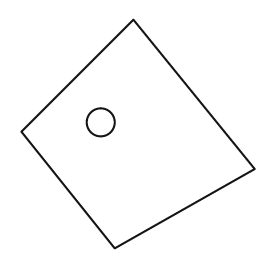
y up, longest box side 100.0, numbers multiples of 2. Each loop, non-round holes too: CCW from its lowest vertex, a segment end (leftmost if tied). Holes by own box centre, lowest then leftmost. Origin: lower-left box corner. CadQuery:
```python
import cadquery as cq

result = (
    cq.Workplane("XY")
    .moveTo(40.0, 0.0)
    .lineTo(100.0, 34.0)
    .lineTo(48.0, 98.0)
    .lineTo(0.0, 50.0)
    .close()
    .moveTo(34.0, 54.0)
    .circle(6.0)
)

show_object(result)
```